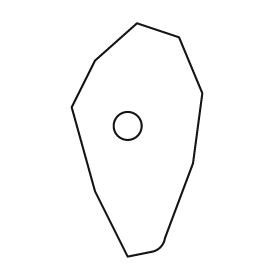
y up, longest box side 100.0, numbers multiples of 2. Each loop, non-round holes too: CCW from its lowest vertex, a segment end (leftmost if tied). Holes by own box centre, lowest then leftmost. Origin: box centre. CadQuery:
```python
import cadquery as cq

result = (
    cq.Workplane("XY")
    .moveTo(-4.0, -50.0)
    .lineTo(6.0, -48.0)
    .threePointArc((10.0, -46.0), (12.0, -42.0))
    .lineTo(24.0, -10.0)
    .lineTo(28.0, 20.0)
    .lineTo(18.0, 44.0)
    .lineTo(0.0, 50.0)
    .lineTo(-18.0, 34.0)
    .lineTo(-28.0, 14.0)
    .lineTo(-18.0, -22.0)
    .close()
    .moveTo(-4.0, 6.0)
    .circle(6.0)
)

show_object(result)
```